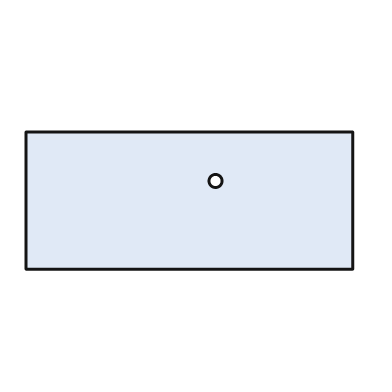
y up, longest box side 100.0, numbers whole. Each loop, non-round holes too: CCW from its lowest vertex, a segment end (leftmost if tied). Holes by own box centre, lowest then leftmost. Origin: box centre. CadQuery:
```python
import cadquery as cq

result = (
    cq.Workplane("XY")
    .moveTo(-50.0, -21.0)
    .lineTo(50.0, -21.0)
    .lineTo(50.0, 21.0)
    .lineTo(-50.0, 21.0)
    .close()
    .moveTo(8.0, 6.0)
    .circle(2.0)
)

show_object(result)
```